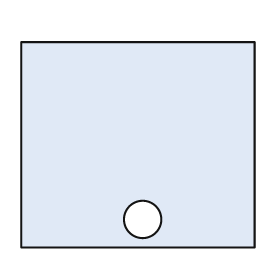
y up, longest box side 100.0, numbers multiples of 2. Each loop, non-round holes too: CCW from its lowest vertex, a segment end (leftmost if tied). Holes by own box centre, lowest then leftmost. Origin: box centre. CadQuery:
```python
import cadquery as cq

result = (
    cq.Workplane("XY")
    .moveTo(-50.0, -44.0)
    .lineTo(50.0, -44.0)
    .lineTo(50.0, 44.0)
    .lineTo(-50.0, 44.0)
    .close()
    .moveTo(2.0, -32.0)
    .circle(8.0)
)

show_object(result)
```